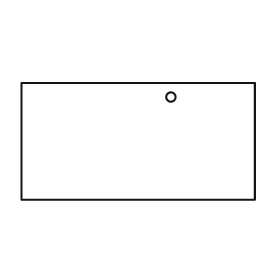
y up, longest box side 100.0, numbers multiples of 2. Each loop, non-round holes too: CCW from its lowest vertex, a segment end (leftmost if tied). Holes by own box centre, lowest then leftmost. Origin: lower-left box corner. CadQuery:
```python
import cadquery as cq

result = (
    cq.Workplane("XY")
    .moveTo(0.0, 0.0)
    .lineTo(100.0, 0.0)
    .lineTo(100.0, 50.0)
    .lineTo(0.0, 50.0)
    .close()
    .moveTo(64.0, 44.0)
    .circle(2.0)
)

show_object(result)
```